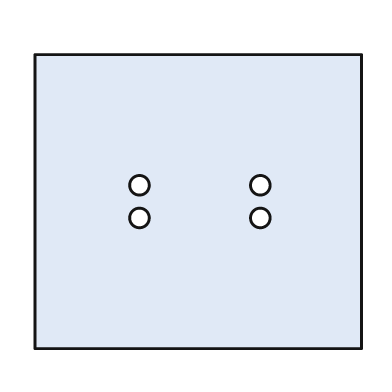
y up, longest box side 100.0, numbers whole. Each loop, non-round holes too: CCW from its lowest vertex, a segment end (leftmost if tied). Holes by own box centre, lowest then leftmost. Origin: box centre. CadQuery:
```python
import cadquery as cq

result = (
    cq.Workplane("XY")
    .moveTo(-50.0, -45.0)
    .lineTo(50.0, -45.0)
    .lineTo(50.0, 45.0)
    .lineTo(-50.0, 45.0)
    .close()
    .moveTo(-18.0, -5.0)
    .circle(3.0)
    .moveTo(19.0, -5.0)
    .circle(3.0)
    .moveTo(-18.0, 5.0)
    .circle(3.0)
    .moveTo(19.0, 5.0)
    .circle(3.0)
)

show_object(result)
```